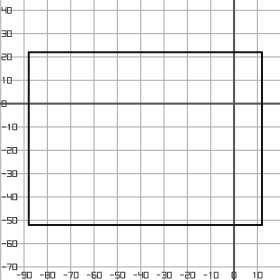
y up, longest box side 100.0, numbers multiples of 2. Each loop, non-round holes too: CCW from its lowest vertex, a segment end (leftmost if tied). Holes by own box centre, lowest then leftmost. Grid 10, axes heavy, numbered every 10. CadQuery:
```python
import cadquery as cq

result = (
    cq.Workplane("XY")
    .moveTo(-88.0, -52.0)
    .lineTo(12.0, -52.0)
    .lineTo(12.0, 22.0)
    .lineTo(-88.0, 22.0)
    .close()
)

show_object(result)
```